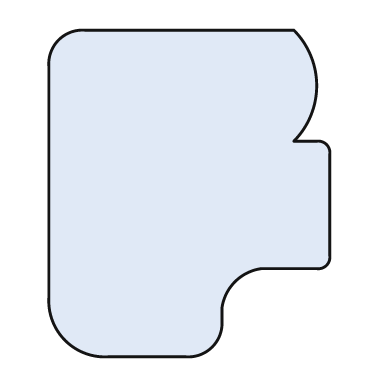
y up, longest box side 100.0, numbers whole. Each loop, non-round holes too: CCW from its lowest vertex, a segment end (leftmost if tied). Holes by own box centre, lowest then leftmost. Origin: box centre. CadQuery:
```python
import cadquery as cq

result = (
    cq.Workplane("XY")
    .moveTo(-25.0, -50.0)
    .lineTo(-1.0, -50.0)
    .threePointArc((7.0, -47.0), (10.0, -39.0))
    .lineTo(10.0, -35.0)
    .threePointArc((14.0, -27.0), (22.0, -23.0))
    .lineTo(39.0, -23.0)
    .threePointArc((42.0, -22.0), (43.0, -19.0))
    .lineTo(43.0, 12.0)
    .threePointArc((42.0, 15.0), (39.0, 16.0))
    .lineTo(32.0, 16.0)
    .threePointArc((39.0, 33.0), (32.0, 50.0))
    .lineTo(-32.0, 50.0)
    .threePointArc((-40.0, 47.0), (-43.0, 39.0))
    .lineTo(-43.0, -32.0)
    .threePointArc((-38.0, -45.0), (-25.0, -50.0))
    .close()
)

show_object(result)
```